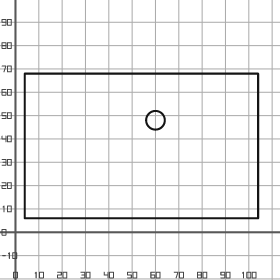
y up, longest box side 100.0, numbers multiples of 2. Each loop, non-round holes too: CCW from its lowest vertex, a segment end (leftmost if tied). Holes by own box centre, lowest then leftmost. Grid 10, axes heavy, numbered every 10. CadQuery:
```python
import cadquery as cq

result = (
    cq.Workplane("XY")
    .moveTo(4.0, 6.0)
    .lineTo(104.0, 6.0)
    .lineTo(104.0, 68.0)
    .lineTo(4.0, 68.0)
    .close()
    .moveTo(60.0, 48.0)
    .circle(4.0)
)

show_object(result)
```